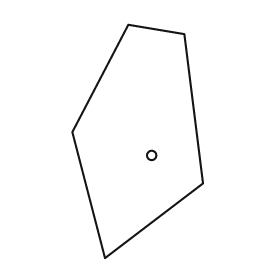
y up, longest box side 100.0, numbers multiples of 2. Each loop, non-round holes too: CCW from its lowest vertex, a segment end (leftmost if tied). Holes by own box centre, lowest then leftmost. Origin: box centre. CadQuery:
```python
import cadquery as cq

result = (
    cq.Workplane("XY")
    .moveTo(-14.0, -50.0)
    .lineTo(28.0, -18.0)
    .lineTo(20.0, 46.0)
    .lineTo(-4.0, 50.0)
    .lineTo(-28.0, 4.0)
    .close()
    .moveTo(6.0, -6.0)
    .circle(2.0)
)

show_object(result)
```